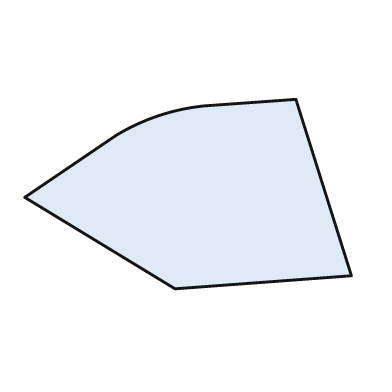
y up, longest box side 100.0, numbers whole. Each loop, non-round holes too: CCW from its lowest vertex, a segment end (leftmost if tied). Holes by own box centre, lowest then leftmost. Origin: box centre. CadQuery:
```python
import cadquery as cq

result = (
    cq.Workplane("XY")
    .moveTo(-4.0, -29.0)
    .lineTo(50.0, -25.0)
    .lineTo(33.0, 29.0)
    .lineTo(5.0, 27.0)
    .threePointArc((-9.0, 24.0), (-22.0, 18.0))
    .lineTo(-50.0, -1.0)
    .close()
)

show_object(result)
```